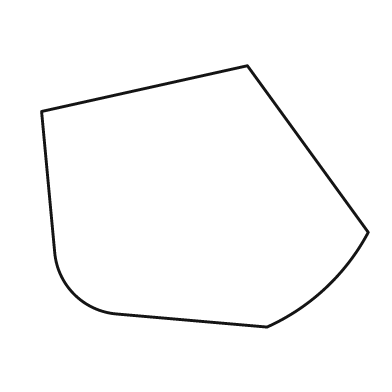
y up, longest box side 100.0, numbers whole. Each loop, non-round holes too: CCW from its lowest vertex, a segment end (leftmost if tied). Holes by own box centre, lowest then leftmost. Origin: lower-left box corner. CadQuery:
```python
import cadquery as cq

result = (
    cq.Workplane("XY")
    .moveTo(69.0, 0.0)
    .threePointArc((87.0, 12.0), (100.0, 29.0))
    .lineTo(63.0, 80.0)
    .lineTo(0.0, 66.0)
    .lineTo(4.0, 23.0)
    .threePointArc((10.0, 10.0), (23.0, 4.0))
    .close()
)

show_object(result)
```